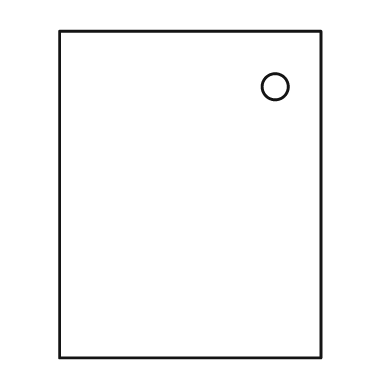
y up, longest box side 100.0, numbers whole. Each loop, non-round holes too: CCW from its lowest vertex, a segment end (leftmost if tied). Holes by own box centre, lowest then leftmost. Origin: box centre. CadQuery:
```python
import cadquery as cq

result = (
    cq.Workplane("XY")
    .moveTo(-40.0, -50.0)
    .lineTo(40.0, -50.0)
    .lineTo(40.0, 50.0)
    .lineTo(-40.0, 50.0)
    .close()
    .moveTo(26.0, 33.0)
    .circle(4.0)
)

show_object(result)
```